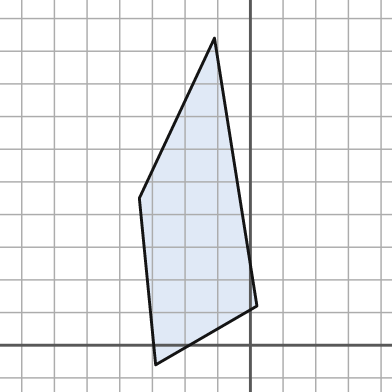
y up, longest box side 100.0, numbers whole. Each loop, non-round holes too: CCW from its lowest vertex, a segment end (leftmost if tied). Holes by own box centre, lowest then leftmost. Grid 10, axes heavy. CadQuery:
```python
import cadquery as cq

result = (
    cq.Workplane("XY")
    .moveTo(-29.0, -6.0)
    .lineTo(2.0, 12.0)
    .lineTo(-11.0, 94.0)
    .lineTo(-34.0, 45.0)
    .close()
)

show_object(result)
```